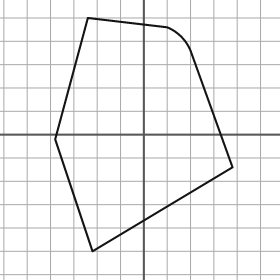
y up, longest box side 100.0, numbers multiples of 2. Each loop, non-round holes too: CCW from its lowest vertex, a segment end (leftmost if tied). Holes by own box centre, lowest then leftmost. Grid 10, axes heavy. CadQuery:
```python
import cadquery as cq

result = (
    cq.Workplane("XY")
    .moveTo(-22.0, -50.0)
    .lineTo(38.0, -14.0)
    .lineTo(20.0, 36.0)
    .threePointArc((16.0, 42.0), (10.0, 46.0))
    .lineTo(-24.0, 50.0)
    .lineTo(-38.0, -2.0)
    .close()
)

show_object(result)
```